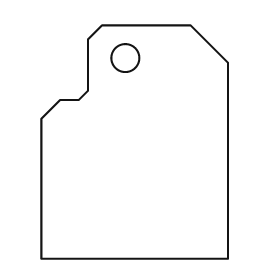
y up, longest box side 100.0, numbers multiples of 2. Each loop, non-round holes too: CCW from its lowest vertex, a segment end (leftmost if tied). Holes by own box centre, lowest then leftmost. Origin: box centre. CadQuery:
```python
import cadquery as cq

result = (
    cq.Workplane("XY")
    .moveTo(-40.0, -50.0)
    .lineTo(40.0, -50.0)
    .lineTo(40.0, 34.0)
    .lineTo(24.0, 50.0)
    .lineTo(-14.0, 50.0)
    .lineTo(-20.0, 44.0)
    .lineTo(-20.0, 22.0)
    .lineTo(-24.0, 18.0)
    .lineTo(-32.0, 18.0)
    .lineTo(-40.0, 10.0)
    .close()
    .moveTo(-4.0, 36.0)
    .circle(6.0)
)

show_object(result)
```